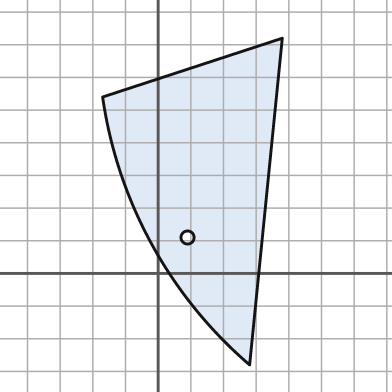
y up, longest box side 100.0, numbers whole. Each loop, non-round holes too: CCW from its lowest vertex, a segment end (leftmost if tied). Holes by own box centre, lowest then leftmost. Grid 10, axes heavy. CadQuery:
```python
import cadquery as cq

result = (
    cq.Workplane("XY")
    .moveTo(28.0, -28.0)
    .lineTo(38.0, 72.0)
    .lineTo(-17.0, 54.0)
    .threePointArc((-2.0, 9.0), (28.0, -28.0))
    .close()
    .moveTo(9.0, 11.0)
    .circle(2.0)
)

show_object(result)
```